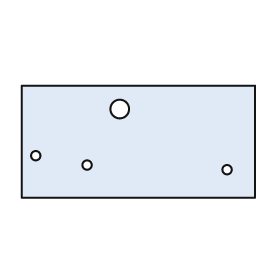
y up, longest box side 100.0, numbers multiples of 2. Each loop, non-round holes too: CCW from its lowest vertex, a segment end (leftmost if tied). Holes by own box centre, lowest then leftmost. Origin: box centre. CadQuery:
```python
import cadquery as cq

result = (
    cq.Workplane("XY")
    .moveTo(-50.0, -24.0)
    .lineTo(50.0, -24.0)
    .lineTo(50.0, 24.0)
    .lineTo(-50.0, 24.0)
    .close()
    .moveTo(38.0, -12.0)
    .circle(2.0)
    .moveTo(-22.0, -10.0)
    .circle(2.0)
    .moveTo(-44.0, -6.0)
    .circle(2.0)
    .moveTo(-8.0, 14.0)
    .circle(4.0)
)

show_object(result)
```